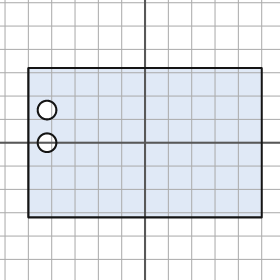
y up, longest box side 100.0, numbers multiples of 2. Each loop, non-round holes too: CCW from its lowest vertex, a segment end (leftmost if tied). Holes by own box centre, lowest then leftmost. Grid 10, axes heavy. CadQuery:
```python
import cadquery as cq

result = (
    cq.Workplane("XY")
    .moveTo(-50.0, -32.0)
    .lineTo(50.0, -32.0)
    .lineTo(50.0, 32.0)
    .lineTo(-50.0, 32.0)
    .close()
    .moveTo(-42.0, 0.0)
    .circle(4.0)
    .moveTo(-42.0, 14.0)
    .circle(4.0)
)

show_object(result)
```